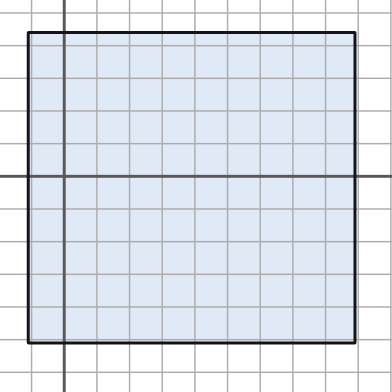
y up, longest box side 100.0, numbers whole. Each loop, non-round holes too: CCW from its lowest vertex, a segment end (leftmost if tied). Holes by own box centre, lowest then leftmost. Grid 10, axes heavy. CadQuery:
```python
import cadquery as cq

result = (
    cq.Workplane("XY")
    .moveTo(-11.0, -51.0)
    .lineTo(89.0, -51.0)
    .lineTo(89.0, 44.0)
    .lineTo(-11.0, 44.0)
    .close()
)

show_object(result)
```